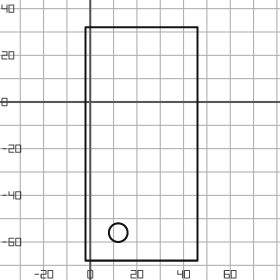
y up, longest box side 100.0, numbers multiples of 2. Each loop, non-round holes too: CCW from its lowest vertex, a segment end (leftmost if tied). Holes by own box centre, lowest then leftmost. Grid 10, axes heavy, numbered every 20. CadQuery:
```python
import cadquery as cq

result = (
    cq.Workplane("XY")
    .moveTo(-2.0, -68.0)
    .lineTo(46.0, -68.0)
    .lineTo(46.0, 32.0)
    .lineTo(-2.0, 32.0)
    .close()
    .moveTo(12.0, -56.0)
    .circle(4.0)
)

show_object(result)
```